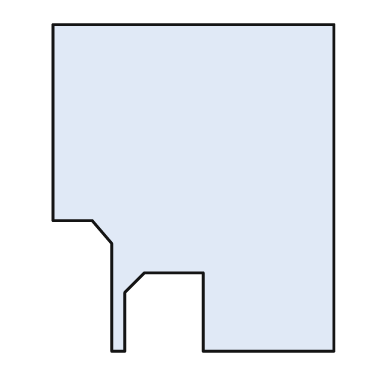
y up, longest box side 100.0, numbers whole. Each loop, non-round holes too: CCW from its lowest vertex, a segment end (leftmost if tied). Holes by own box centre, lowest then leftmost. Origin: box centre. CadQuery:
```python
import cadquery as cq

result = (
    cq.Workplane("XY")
    .moveTo(-25.0, -50.0)
    .lineTo(-21.0, -50.0)
    .lineTo(-21.0, -32.0)
    .lineTo(-15.0, -26.0)
    .lineTo(3.0, -26.0)
    .lineTo(3.0, -50.0)
    .lineTo(43.0, -50.0)
    .lineTo(43.0, 50.0)
    .lineTo(-43.0, 50.0)
    .lineTo(-43.0, -10.0)
    .lineTo(-31.0, -10.0)
    .lineTo(-25.0, -17.0)
    .close()
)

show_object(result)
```